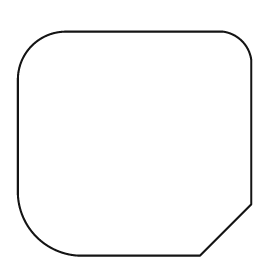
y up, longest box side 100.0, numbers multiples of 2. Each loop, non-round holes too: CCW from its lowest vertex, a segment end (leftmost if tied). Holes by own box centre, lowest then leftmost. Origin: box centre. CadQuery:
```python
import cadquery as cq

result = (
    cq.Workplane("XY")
    .moveTo(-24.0, -48.0)
    .lineTo(28.0, -48.0)
    .lineTo(50.0, -26.0)
    .lineTo(50.0, 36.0)
    .threePointArc((46.0, 44.0), (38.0, 48.0))
    .lineTo(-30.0, 48.0)
    .threePointArc((-44.0, 42.0), (-50.0, 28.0))
    .lineTo(-50.0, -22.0)
    .threePointArc((-42.0, -40.0), (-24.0, -48.0))
    .close()
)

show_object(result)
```